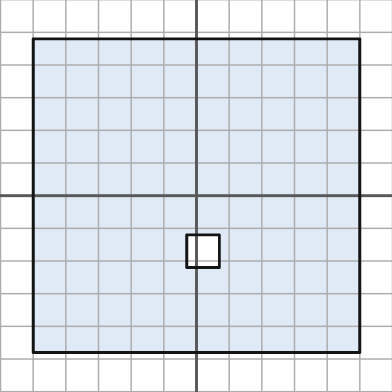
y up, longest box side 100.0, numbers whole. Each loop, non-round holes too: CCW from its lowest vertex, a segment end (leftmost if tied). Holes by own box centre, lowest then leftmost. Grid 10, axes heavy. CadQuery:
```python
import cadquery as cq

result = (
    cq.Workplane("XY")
    .moveTo(-50.0, -48.0)
    .lineTo(50.0, -48.0)
    .lineTo(50.0, 48.0)
    .lineTo(-50.0, 48.0)
    .close()
    .moveTo(-3.0, -22.0)
    .lineTo(7.0, -22.0)
    .lineTo(7.0, -12.0)
    .lineTo(-3.0, -12.0)
    .close()
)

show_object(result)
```